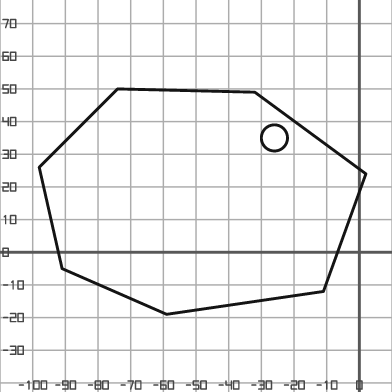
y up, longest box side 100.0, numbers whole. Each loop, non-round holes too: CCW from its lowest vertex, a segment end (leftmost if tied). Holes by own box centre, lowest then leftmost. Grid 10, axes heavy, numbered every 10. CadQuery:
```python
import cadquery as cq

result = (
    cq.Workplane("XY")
    .moveTo(-59.0, -19.0)
    .lineTo(-11.0, -12.0)
    .lineTo(2.0, 24.0)
    .lineTo(-32.0, 49.0)
    .lineTo(-74.0, 50.0)
    .lineTo(-98.0, 26.0)
    .lineTo(-91.0, -5.0)
    .close()
    .moveTo(-26.0, 35.0)
    .circle(4.0)
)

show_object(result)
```